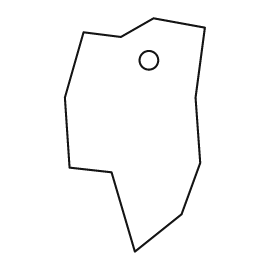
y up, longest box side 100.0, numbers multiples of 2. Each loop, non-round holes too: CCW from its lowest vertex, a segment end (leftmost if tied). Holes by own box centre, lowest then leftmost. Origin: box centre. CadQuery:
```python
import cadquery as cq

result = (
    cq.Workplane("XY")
    .moveTo(0.0, -50.0)
    .lineTo(20.0, -34.0)
    .lineTo(28.0, -12.0)
    .lineTo(26.0, 16.0)
    .lineTo(30.0, 46.0)
    .lineTo(8.0, 50.0)
    .lineTo(-6.0, 42.0)
    .lineTo(-22.0, 44.0)
    .lineTo(-30.0, 16.0)
    .lineTo(-28.0, -14.0)
    .lineTo(-10.0, -16.0)
    .close()
    .moveTo(6.0, 32.0)
    .circle(4.0)
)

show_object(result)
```